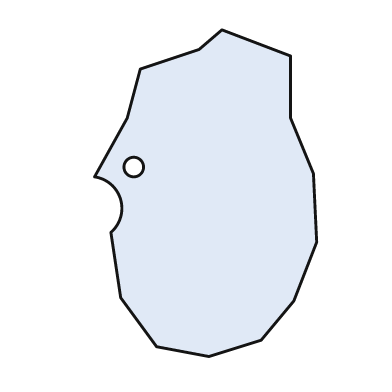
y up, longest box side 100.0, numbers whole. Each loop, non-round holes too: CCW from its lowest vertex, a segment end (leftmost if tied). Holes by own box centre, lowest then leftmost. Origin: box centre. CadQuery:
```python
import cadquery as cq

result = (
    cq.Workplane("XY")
    .moveTo(1.0, -50.0)
    .lineTo(17.0, -45.0)
    .lineTo(27.0, -33.0)
    .lineTo(34.0, -15.0)
    .lineTo(33.0, 6.0)
    .lineTo(26.0, 23.0)
    .lineTo(26.0, 42.0)
    .lineTo(5.0, 50.0)
    .lineTo(-2.0, 44.0)
    .lineTo(-20.0, 38.0)
    .lineTo(-24.0, 23.0)
    .lineTo(-34.0, 5.0)
    .threePointArc((-26.0, -2.0), (-29.0, -12.0))
    .lineTo(-26.0, -32.0)
    .lineTo(-15.0, -47.0)
    .close()
    .moveTo(-22.0, 8.0)
    .circle(3.0)
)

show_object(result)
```